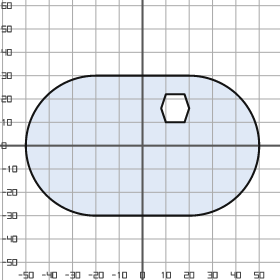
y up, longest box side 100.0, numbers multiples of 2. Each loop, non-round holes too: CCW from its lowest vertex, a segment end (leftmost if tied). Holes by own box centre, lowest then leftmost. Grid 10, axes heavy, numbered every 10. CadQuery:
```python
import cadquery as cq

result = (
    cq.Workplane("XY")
    .moveTo(-20.0, -30.0)
    .lineTo(20.0, -30.0)
    .threePointArc((50.0, 0.0), (20.0, 30.0))
    .lineTo(-20.0, 30.0)
    .threePointArc((-50.0, 0.0), (-20.0, -30.0))
    .close()
    .moveTo(10.0, 10.0)
    .lineTo(18.0, 10.0)
    .lineTo(20.0, 16.0)
    .lineTo(18.0, 22.0)
    .lineTo(10.0, 22.0)
    .lineTo(8.0, 16.0)
    .close()
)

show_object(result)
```